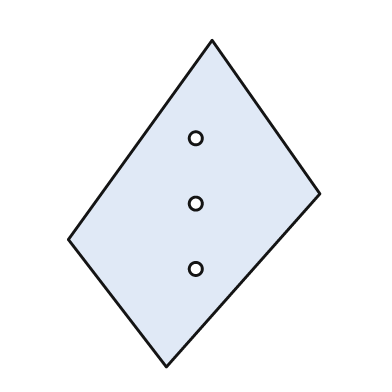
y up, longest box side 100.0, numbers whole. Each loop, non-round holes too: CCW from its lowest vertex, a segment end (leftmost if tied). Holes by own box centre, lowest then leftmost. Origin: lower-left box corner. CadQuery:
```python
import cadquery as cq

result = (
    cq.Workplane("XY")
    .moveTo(30.0, 0.0)
    .lineTo(77.0, 53.0)
    .lineTo(44.0, 100.0)
    .lineTo(0.0, 39.0)
    .close()
    .moveTo(39.0, 30.0)
    .circle(2.0)
    .moveTo(39.0, 50.0)
    .circle(2.0)
    .moveTo(39.0, 70.0)
    .circle(2.0)
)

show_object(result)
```